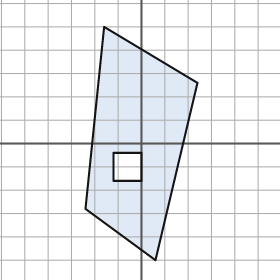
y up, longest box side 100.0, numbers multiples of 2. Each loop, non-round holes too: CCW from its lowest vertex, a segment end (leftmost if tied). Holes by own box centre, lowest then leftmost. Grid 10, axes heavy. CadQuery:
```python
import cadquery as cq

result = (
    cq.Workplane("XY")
    .moveTo(6.0, -50.0)
    .lineTo(24.0, 26.0)
    .lineTo(-16.0, 50.0)
    .lineTo(-24.0, -28.0)
    .close()
    .moveTo(-12.0, -16.0)
    .lineTo(0.0, -16.0)
    .lineTo(0.0, -4.0)
    .lineTo(-12.0, -4.0)
    .close()
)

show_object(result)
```